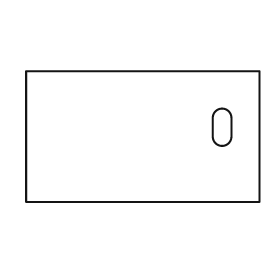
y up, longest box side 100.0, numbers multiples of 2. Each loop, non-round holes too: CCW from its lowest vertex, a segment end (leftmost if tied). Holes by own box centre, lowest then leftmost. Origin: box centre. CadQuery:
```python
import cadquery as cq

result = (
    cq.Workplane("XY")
    .moveTo(-50.0, -28.0)
    .lineTo(50.0, -28.0)
    .lineTo(50.0, 28.0)
    .lineTo(-50.0, 28.0)
    .close()
    .moveTo(30.0, 0.0)
    .threePointArc((34.0, -4.0), (38.0, 0.0))
    .lineTo(38.0, 8.0)
    .threePointArc((34.0, 12.0), (30.0, 8.0))
    .close()
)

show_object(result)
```